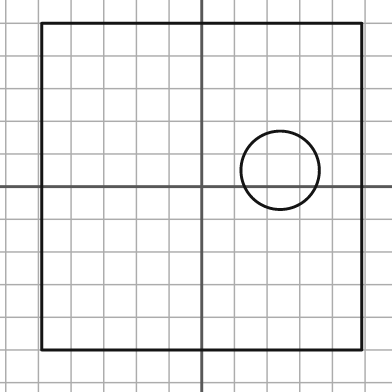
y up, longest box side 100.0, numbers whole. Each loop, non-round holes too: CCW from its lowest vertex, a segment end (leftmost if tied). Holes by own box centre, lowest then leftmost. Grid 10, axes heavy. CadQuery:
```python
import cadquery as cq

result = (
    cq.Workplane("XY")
    .moveTo(-49.0, -50.0)
    .lineTo(49.0, -50.0)
    .lineTo(49.0, 50.0)
    .lineTo(-49.0, 50.0)
    .close()
    .moveTo(24.0, 5.0)
    .circle(12.0)
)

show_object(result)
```